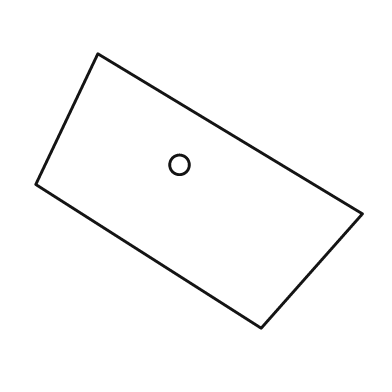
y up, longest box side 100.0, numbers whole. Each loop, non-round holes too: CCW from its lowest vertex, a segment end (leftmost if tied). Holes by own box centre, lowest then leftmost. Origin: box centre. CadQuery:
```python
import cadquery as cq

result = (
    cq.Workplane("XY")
    .moveTo(19.0, -42.0)
    .lineTo(50.0, -7.0)
    .lineTo(-31.0, 42.0)
    .lineTo(-50.0, 2.0)
    .close()
    .moveTo(-6.0, 8.0)
    .circle(3.0)
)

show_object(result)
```